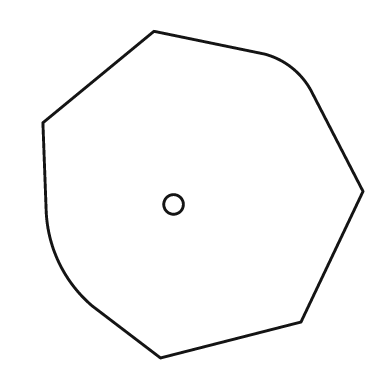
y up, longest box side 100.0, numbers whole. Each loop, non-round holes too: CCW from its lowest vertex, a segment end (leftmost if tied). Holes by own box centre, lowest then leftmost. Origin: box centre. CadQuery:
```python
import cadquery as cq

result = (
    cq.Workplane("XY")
    .moveTo(-13.0, -50.0)
    .lineTo(30.0, -39.0)
    .lineTo(49.0, 1.0)
    .lineTo(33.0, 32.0)
    .threePointArc((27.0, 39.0), (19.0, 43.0))
    .lineTo(-15.0, 50.0)
    .lineTo(-49.0, 22.0)
    .lineTo(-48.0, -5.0)
    .threePointArc((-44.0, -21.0), (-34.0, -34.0))
    .close()
    .moveTo(-9.0, -3.0)
    .circle(3.0)
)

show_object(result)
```